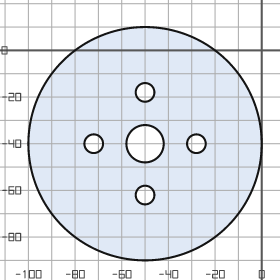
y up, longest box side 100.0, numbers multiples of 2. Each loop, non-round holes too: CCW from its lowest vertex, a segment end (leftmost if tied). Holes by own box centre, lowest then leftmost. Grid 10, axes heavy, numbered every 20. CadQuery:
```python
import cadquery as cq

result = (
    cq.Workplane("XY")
    .moveTo(-50.0, -40.0)
    .circle(50.0)
    .moveTo(-50.0, -62.0)
    .circle(4.0)
    .moveTo(-72.0, -40.0)
    .circle(4.0)
    .moveTo(-50.0, -40.0)
    .circle(8.0)
    .moveTo(-28.0, -40.0)
    .circle(4.0)
    .moveTo(-50.0, -18.0)
    .circle(4.0)
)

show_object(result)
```